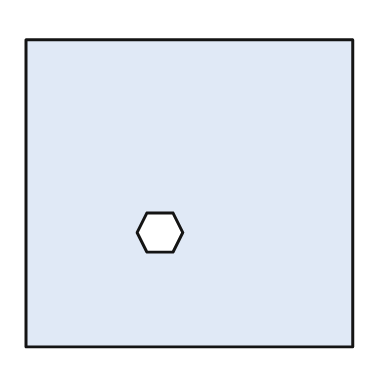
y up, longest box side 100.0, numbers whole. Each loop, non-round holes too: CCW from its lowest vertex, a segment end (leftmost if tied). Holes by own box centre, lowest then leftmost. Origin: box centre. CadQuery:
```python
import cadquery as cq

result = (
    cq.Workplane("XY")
    .moveTo(-50.0, -47.0)
    .lineTo(50.0, -47.0)
    .lineTo(50.0, 47.0)
    .lineTo(-50.0, 47.0)
    .close()
    .moveTo(-13.0, -18.0)
    .lineTo(-5.0, -18.0)
    .lineTo(-2.0, -12.0)
    .lineTo(-5.0, -6.0)
    .lineTo(-13.0, -6.0)
    .lineTo(-16.0, -12.0)
    .close()
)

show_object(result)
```